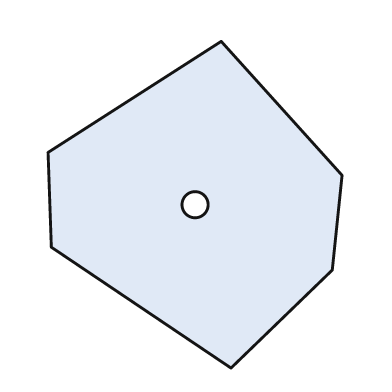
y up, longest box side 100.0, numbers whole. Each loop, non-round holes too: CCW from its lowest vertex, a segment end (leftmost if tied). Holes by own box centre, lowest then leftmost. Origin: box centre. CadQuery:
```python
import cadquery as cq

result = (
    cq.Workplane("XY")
    .moveTo(11.0, -50.0)
    .lineTo(42.0, -20.0)
    .lineTo(45.0, 9.0)
    .lineTo(8.0, 50.0)
    .lineTo(-45.0, 16.0)
    .lineTo(-44.0, -13.0)
    .close()
    .moveTo(0.0, 0.0)
    .circle(4.0)
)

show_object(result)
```